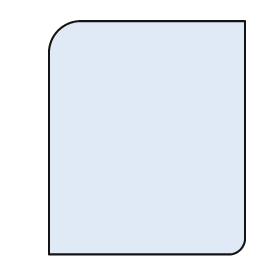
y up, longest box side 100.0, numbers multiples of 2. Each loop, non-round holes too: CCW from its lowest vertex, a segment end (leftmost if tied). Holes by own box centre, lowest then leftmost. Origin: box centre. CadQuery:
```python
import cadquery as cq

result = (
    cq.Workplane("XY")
    .moveTo(-42.0, -50.0)
    .lineTo(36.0, -50.0)
    .threePointArc((40.0, -48.0), (42.0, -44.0))
    .lineTo(42.0, 50.0)
    .lineTo(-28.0, 50.0)
    .threePointArc((-38.0, 46.0), (-42.0, 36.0))
    .close()
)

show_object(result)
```